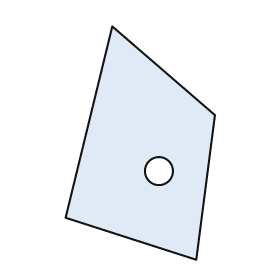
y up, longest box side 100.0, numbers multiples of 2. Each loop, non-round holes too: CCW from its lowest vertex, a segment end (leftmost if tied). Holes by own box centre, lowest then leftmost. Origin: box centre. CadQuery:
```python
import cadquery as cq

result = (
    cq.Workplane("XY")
    .moveTo(24.0, -50.0)
    .lineTo(32.0, 12.0)
    .lineTo(-12.0, 50.0)
    .lineTo(-32.0, -32.0)
    .close()
    .moveTo(8.0, -12.0)
    .circle(6.0)
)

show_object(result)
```